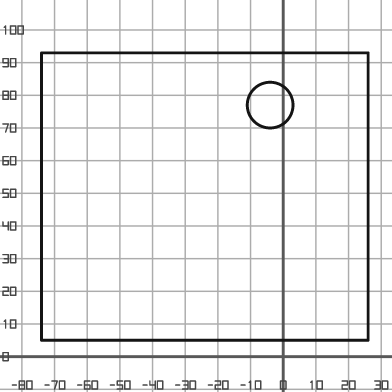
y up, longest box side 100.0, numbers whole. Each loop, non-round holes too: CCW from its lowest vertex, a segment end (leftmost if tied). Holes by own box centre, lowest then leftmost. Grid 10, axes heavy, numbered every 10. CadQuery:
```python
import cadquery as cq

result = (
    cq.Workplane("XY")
    .moveTo(-74.0, 5.0)
    .lineTo(26.0, 5.0)
    .lineTo(26.0, 93.0)
    .lineTo(-74.0, 93.0)
    .close()
    .moveTo(-4.0, 77.0)
    .circle(7.0)
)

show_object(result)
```